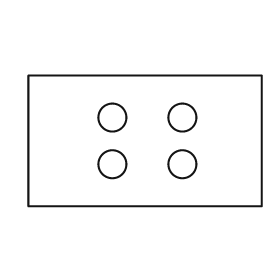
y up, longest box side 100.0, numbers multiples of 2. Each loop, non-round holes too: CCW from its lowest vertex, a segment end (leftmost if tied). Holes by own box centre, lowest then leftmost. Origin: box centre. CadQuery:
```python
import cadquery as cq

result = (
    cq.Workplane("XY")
    .moveTo(-50.0, -28.0)
    .lineTo(50.0, -28.0)
    .lineTo(50.0, 28.0)
    .lineTo(-50.0, 28.0)
    .close()
    .moveTo(-14.0, -10.0)
    .circle(6.0)
    .moveTo(16.0, -10.0)
    .circle(6.0)
    .moveTo(-14.0, 10.0)
    .circle(6.0)
    .moveTo(16.0, 10.0)
    .circle(6.0)
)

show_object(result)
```